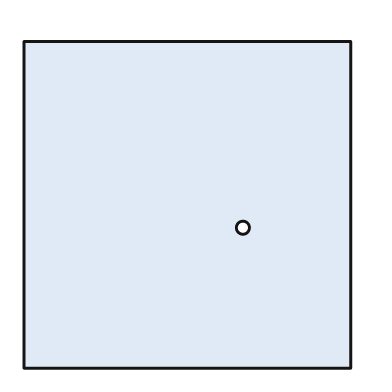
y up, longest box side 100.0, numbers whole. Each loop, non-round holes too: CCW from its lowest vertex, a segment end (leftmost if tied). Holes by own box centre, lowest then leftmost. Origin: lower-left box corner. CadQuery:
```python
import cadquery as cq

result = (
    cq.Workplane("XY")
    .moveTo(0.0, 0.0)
    .lineTo(100.0, 0.0)
    .lineTo(100.0, 100.0)
    .lineTo(0.0, 100.0)
    .close()
    .moveTo(67.0, 43.0)
    .circle(2.0)
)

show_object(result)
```